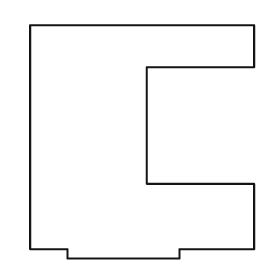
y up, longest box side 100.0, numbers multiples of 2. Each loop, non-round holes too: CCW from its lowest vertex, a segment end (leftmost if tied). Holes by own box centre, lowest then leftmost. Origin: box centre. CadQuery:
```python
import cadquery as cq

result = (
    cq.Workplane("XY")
    .moveTo(-32.0, -50.0)
    .lineTo(16.0, -50.0)
    .lineTo(16.0, -46.0)
    .lineTo(48.0, -46.0)
    .lineTo(48.0, -18.0)
    .lineTo(2.0, -18.0)
    .lineTo(2.0, 32.0)
    .lineTo(48.0, 32.0)
    .lineTo(48.0, 50.0)
    .lineTo(-48.0, 50.0)
    .lineTo(-48.0, -46.0)
    .lineTo(-32.0, -46.0)
    .close()
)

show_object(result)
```